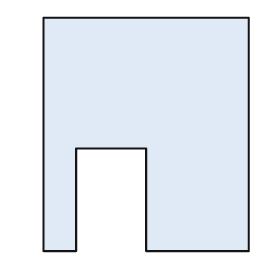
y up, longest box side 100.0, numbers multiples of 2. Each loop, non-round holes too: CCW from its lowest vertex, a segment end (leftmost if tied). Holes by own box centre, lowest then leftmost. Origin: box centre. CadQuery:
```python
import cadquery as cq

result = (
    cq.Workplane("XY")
    .moveTo(-44.0, -50.0)
    .lineTo(-30.0, -50.0)
    .lineTo(-30.0, -6.0)
    .lineTo(0.0, -6.0)
    .lineTo(0.0, -50.0)
    .lineTo(44.0, -50.0)
    .lineTo(44.0, 50.0)
    .lineTo(-44.0, 50.0)
    .close()
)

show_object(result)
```